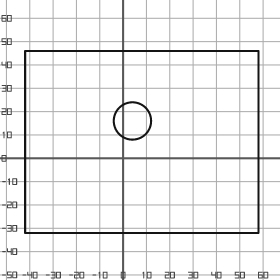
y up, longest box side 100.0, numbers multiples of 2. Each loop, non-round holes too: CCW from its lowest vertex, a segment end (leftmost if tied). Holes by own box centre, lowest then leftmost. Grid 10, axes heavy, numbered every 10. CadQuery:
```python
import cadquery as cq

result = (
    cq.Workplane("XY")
    .moveTo(-42.0, -32.0)
    .lineTo(58.0, -32.0)
    .lineTo(58.0, 46.0)
    .lineTo(-42.0, 46.0)
    .close()
    .moveTo(4.0, 16.0)
    .circle(8.0)
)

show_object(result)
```